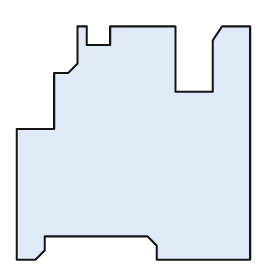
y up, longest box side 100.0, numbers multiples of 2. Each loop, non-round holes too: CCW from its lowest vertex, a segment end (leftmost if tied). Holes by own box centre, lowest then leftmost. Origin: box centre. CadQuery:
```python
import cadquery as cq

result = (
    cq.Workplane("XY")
    .moveTo(-50.0, -50.0)
    .lineTo(-42.0, -50.0)
    .lineTo(-38.0, -46.0)
    .lineTo(-38.0, -40.0)
    .lineTo(6.0, -40.0)
    .lineTo(10.0, -44.0)
    .lineTo(10.0, -50.0)
    .lineTo(50.0, -50.0)
    .lineTo(50.0, 50.0)
    .lineTo(38.0, 50.0)
    .lineTo(34.0, 44.0)
    .lineTo(34.0, 22.0)
    .lineTo(18.0, 22.0)
    .lineTo(18.0, 50.0)
    .lineTo(-10.0, 50.0)
    .lineTo(-10.0, 42.0)
    .lineTo(-20.0, 42.0)
    .lineTo(-20.0, 50.0)
    .lineTo(-24.0, 50.0)
    .lineTo(-24.0, 34.0)
    .lineTo(-28.0, 30.0)
    .lineTo(-34.0, 30.0)
    .lineTo(-34.0, 6.0)
    .lineTo(-50.0, 6.0)
    .close()
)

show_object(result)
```